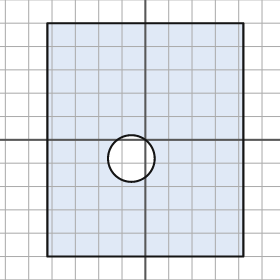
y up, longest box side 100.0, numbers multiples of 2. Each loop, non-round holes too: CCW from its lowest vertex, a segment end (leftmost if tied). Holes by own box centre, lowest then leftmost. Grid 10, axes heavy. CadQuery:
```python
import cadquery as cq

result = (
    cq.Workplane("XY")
    .moveTo(-42.0, -50.0)
    .lineTo(42.0, -50.0)
    .lineTo(42.0, 50.0)
    .lineTo(-42.0, 50.0)
    .close()
    .moveTo(-6.0, -8.0)
    .circle(10.0)
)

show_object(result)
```